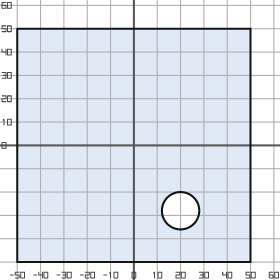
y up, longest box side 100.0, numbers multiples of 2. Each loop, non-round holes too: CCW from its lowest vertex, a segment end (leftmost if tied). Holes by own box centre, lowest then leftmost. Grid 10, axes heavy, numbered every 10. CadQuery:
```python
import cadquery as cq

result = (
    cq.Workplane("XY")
    .moveTo(-50.0, -50.0)
    .lineTo(50.0, -50.0)
    .lineTo(50.0, 50.0)
    .lineTo(-50.0, 50.0)
    .close()
    .moveTo(20.0, -28.0)
    .circle(8.0)
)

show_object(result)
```